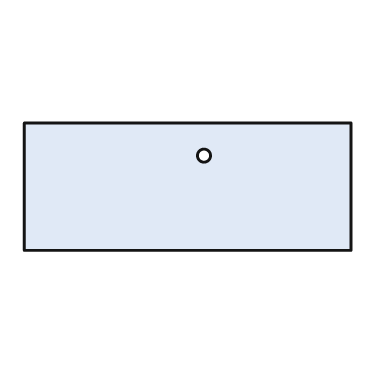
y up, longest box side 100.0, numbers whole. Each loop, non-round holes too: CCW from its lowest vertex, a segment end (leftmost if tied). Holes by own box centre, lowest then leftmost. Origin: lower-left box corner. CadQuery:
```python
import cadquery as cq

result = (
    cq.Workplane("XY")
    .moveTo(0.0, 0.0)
    .lineTo(100.0, 0.0)
    .lineTo(100.0, 39.0)
    .lineTo(0.0, 39.0)
    .close()
    .moveTo(55.0, 29.0)
    .circle(2.0)
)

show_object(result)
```